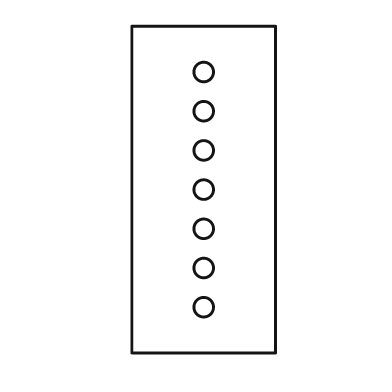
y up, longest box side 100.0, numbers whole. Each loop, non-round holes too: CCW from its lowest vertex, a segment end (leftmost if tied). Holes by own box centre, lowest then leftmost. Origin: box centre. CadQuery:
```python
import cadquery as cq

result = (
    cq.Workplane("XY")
    .moveTo(-22.0, -50.0)
    .lineTo(22.0, -50.0)
    .lineTo(22.0, 50.0)
    .lineTo(-22.0, 50.0)
    .close()
    .moveTo(0.0, -36.0)
    .circle(3.0)
    .moveTo(0.0, -24.0)
    .circle(3.0)
    .moveTo(0.0, -12.0)
    .circle(3.0)
    .moveTo(0.0, 0.0)
    .circle(3.0)
    .moveTo(0.0, 12.0)
    .circle(3.0)
    .moveTo(0.0, 24.0)
    .circle(3.0)
    .moveTo(0.0, 36.0)
    .circle(3.0)
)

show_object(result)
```